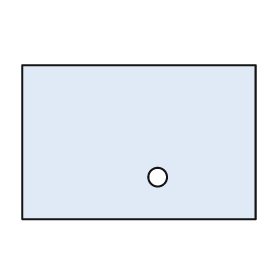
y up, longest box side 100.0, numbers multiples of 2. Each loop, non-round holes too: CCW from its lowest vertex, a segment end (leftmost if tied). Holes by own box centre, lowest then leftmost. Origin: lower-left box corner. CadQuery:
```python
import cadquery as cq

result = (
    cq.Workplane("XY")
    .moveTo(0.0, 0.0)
    .lineTo(100.0, 0.0)
    .lineTo(100.0, 66.0)
    .lineTo(0.0, 66.0)
    .close()
    .moveTo(58.0, 18.0)
    .circle(4.0)
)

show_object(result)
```